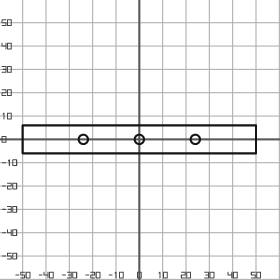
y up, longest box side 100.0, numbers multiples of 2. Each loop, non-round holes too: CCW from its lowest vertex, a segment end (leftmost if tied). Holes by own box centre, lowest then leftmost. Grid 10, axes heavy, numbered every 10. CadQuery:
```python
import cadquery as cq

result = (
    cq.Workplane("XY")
    .moveTo(-50.0, -6.0)
    .lineTo(50.0, -6.0)
    .lineTo(50.0, 6.0)
    .lineTo(-50.0, 6.0)
    .close()
    .moveTo(-24.0, 0.0)
    .circle(2.0)
    .moveTo(0.0, 0.0)
    .circle(2.0)
    .moveTo(24.0, 0.0)
    .circle(2.0)
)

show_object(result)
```